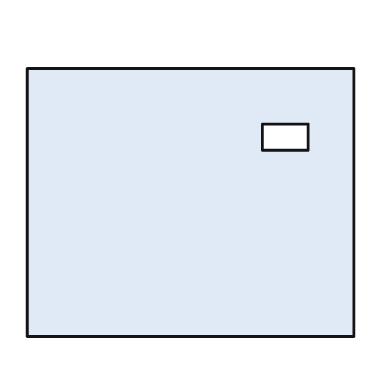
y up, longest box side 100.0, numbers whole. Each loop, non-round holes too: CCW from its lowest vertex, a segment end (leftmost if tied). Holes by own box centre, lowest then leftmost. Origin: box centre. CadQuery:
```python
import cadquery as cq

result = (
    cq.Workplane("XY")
    .moveTo(-50.0, -41.0)
    .lineTo(50.0, -41.0)
    .lineTo(50.0, 41.0)
    .lineTo(-50.0, 41.0)
    .close()
    .moveTo(22.0, 16.0)
    .lineTo(36.0, 16.0)
    .lineTo(36.0, 24.0)
    .lineTo(22.0, 24.0)
    .close()
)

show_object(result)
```